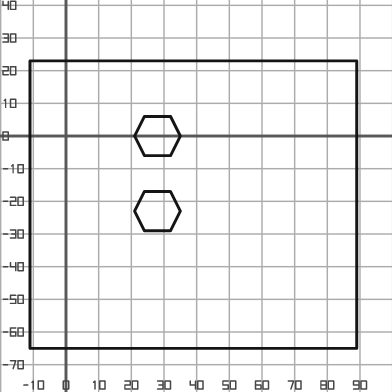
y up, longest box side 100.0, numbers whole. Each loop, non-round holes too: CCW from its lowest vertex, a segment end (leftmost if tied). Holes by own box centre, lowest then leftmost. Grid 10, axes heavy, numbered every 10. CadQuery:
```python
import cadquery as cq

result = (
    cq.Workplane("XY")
    .moveTo(-11.0, -65.0)
    .lineTo(89.0, -65.0)
    .lineTo(89.0, 23.0)
    .lineTo(-11.0, 23.0)
    .close()
    .moveTo(24.0, -29.0)
    .lineTo(32.0, -29.0)
    .lineTo(35.0, -23.0)
    .lineTo(32.0, -17.0)
    .lineTo(24.0, -17.0)
    .lineTo(21.0, -23.0)
    .close()
    .moveTo(24.0, -6.0)
    .lineTo(32.0, -6.0)
    .lineTo(35.0, 0.0)
    .lineTo(32.0, 6.0)
    .lineTo(24.0, 6.0)
    .lineTo(21.0, 0.0)
    .close()
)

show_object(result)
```